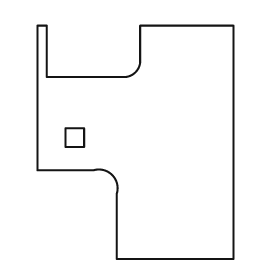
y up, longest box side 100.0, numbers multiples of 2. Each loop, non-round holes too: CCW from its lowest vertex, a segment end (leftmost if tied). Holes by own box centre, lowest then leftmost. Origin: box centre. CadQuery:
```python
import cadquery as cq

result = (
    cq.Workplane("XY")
    .moveTo(-8.0, -50.0)
    .lineTo(42.0, -50.0)
    .lineTo(42.0, 50.0)
    .lineTo(2.0, 50.0)
    .lineTo(2.0, 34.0)
    .threePointArc((0.0, 30.0), (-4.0, 28.0))
    .lineTo(-38.0, 28.0)
    .lineTo(-38.0, 50.0)
    .lineTo(-42.0, 50.0)
    .lineTo(-42.0, -12.0)
    .lineTo(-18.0, -12.0)
    .threePointArc((-10.0, -14.0), (-8.0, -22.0))
    .close()
    .moveTo(-30.0, -2.0)
    .lineTo(-22.0, -2.0)
    .lineTo(-22.0, 6.0)
    .lineTo(-30.0, 6.0)
    .close()
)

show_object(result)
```